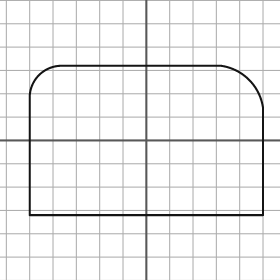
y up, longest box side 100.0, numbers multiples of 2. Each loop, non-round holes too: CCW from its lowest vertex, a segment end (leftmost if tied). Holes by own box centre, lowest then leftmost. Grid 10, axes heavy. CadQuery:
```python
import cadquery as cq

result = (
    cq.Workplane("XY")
    .moveTo(-50.0, -32.0)
    .lineTo(50.0, -32.0)
    .lineTo(50.0, 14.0)
    .threePointArc((44.0, 26.0), (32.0, 32.0))
    .lineTo(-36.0, 32.0)
    .threePointArc((-46.0, 28.0), (-50.0, 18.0))
    .close()
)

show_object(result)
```